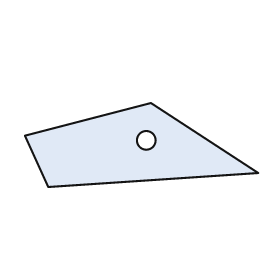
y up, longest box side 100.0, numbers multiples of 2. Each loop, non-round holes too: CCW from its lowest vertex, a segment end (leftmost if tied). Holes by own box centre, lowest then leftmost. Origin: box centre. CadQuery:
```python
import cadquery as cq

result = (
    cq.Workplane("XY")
    .moveTo(-40.0, -18.0)
    .lineTo(50.0, -12.0)
    .lineTo(4.0, 18.0)
    .lineTo(-50.0, 4.0)
    .close()
    .moveTo(2.0, 2.0)
    .circle(4.0)
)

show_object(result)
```